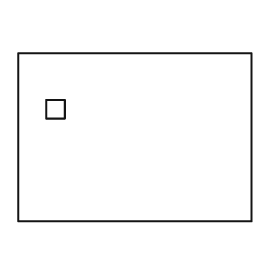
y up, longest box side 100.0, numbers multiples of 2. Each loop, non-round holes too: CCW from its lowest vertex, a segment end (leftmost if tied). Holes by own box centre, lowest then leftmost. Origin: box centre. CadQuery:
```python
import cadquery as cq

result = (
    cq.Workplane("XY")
    .moveTo(-50.0, -36.0)
    .lineTo(50.0, -36.0)
    .lineTo(50.0, 36.0)
    .lineTo(-50.0, 36.0)
    .close()
    .moveTo(-38.0, 8.0)
    .lineTo(-30.0, 8.0)
    .lineTo(-30.0, 16.0)
    .lineTo(-38.0, 16.0)
    .close()
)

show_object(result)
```